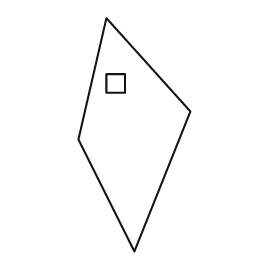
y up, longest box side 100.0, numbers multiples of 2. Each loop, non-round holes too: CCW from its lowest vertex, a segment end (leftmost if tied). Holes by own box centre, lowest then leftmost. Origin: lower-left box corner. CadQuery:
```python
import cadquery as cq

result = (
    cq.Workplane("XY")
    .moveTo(24.0, 0.0)
    .lineTo(48.0, 60.0)
    .lineTo(12.0, 100.0)
    .lineTo(0.0, 48.0)
    .close()
    .moveTo(12.0, 68.0)
    .lineTo(20.0, 68.0)
    .lineTo(20.0, 76.0)
    .lineTo(12.0, 76.0)
    .close()
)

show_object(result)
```